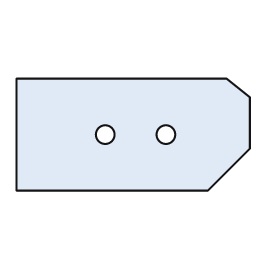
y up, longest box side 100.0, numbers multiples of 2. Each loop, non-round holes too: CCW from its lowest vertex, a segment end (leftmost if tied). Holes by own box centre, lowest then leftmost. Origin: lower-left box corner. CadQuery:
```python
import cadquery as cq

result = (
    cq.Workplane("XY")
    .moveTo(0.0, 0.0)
    .lineTo(82.0, 0.0)
    .lineTo(100.0, 18.0)
    .lineTo(100.0, 40.0)
    .lineTo(90.0, 48.0)
    .lineTo(0.0, 48.0)
    .close()
    .moveTo(38.0, 24.0)
    .circle(4.0)
    .moveTo(64.0, 24.0)
    .circle(4.0)
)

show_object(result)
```